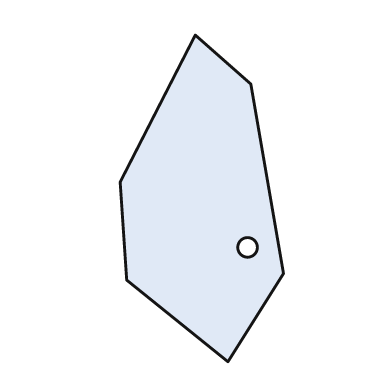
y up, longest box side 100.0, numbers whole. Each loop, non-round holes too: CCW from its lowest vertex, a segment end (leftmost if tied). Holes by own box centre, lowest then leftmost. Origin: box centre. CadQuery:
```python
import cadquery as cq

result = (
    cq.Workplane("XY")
    .moveTo(8.0, -50.0)
    .lineTo(25.0, -23.0)
    .lineTo(15.0, 35.0)
    .lineTo(-2.0, 50.0)
    .lineTo(-25.0, 5.0)
    .lineTo(-23.0, -25.0)
    .close()
    .moveTo(14.0, -15.0)
    .circle(3.0)
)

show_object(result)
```